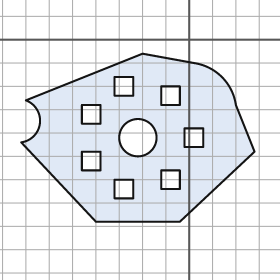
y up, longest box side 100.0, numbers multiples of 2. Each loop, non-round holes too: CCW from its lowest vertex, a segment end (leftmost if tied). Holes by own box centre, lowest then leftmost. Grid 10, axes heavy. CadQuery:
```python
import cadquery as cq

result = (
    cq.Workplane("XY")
    .moveTo(-40.0, -78.0)
    .lineTo(-4.0, -78.0)
    .lineTo(28.0, -48.0)
    .lineTo(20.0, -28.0)
    .threePointArc((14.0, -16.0), (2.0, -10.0))
    .lineTo(-20.0, -6.0)
    .lineTo(-70.0, -26.0)
    .threePointArc((-64.0, -36.0), (-72.0, -44.0))
    .close()
    .moveTo(-32.0, -68.0)
    .lineTo(-24.0, -68.0)
    .lineTo(-24.0, -60.0)
    .lineTo(-32.0, -60.0)
    .close()
    .moveTo(-12.0, -64.0)
    .lineTo(-4.0, -64.0)
    .lineTo(-4.0, -56.0)
    .lineTo(-12.0, -56.0)
    .close()
    .moveTo(-46.0, -56.0)
    .lineTo(-38.0, -56.0)
    .lineTo(-38.0, -48.0)
    .lineTo(-46.0, -48.0)
    .close()
    .moveTo(-22.0, -42.0)
    .circle(8.0)
    .moveTo(-2.0, -46.0)
    .lineTo(6.0, -46.0)
    .lineTo(6.0, -38.0)
    .lineTo(-2.0, -38.0)
    .close()
    .moveTo(-46.0, -36.0)
    .lineTo(-38.0, -36.0)
    .lineTo(-38.0, -28.0)
    .lineTo(-46.0, -28.0)
    .close()
    .moveTo(-12.0, -28.0)
    .lineTo(-4.0, -28.0)
    .lineTo(-4.0, -20.0)
    .lineTo(-12.0, -20.0)
    .close()
    .moveTo(-32.0, -24.0)
    .lineTo(-24.0, -24.0)
    .lineTo(-24.0, -16.0)
    .lineTo(-32.0, -16.0)
    .close()
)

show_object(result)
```